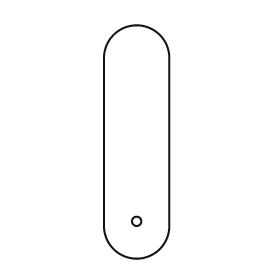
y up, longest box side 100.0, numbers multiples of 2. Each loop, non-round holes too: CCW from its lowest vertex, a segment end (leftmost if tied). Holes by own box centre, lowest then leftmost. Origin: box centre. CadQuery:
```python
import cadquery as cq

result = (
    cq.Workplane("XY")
    .moveTo(-14.0, -36.0)
    .threePointArc((0.0, -50.0), (14.0, -36.0))
    .lineTo(14.0, 36.0)
    .threePointArc((0.0, 50.0), (-14.0, 36.0))
    .close()
    .moveTo(0.0, -34.0)
    .circle(2.0)
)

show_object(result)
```